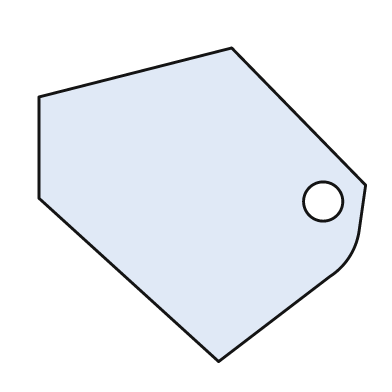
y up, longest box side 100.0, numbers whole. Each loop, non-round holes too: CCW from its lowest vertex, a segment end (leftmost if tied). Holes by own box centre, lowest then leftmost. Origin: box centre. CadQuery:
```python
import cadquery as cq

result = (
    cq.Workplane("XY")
    .moveTo(5.0, -48.0)
    .lineTo(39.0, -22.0)
    .threePointArc((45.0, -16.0), (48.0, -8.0))
    .lineTo(50.0, 6.0)
    .lineTo(9.0, 48.0)
    .lineTo(-50.0, 33.0)
    .lineTo(-50.0, 2.0)
    .close()
    .moveTo(37.0, 1.0)
    .circle(6.0)
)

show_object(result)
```